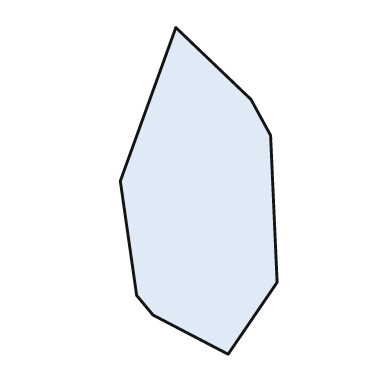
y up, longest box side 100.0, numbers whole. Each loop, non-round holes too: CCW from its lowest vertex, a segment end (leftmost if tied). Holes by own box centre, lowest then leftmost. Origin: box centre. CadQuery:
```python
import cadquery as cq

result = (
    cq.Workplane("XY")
    .moveTo(9.0, -50.0)
    .lineTo(24.0, -28.0)
    .lineTo(22.0, 17.0)
    .lineTo(16.0, 28.0)
    .lineTo(-7.0, 50.0)
    .lineTo(-24.0, 3.0)
    .lineTo(-19.0, -32.0)
    .lineTo(-14.0, -38.0)
    .close()
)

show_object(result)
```